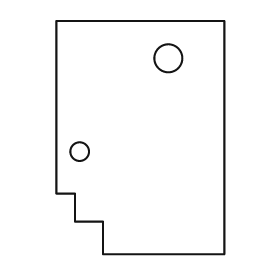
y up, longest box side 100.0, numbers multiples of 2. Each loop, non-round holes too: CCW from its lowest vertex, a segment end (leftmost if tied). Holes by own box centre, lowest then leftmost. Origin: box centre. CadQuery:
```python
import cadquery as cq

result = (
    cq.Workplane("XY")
    .moveTo(-16.0, -50.0)
    .lineTo(36.0, -50.0)
    .lineTo(36.0, 50.0)
    .lineTo(-36.0, 50.0)
    .lineTo(-36.0, -24.0)
    .lineTo(-28.0, -24.0)
    .lineTo(-28.0, -36.0)
    .lineTo(-16.0, -36.0)
    .close()
    .moveTo(-26.0, -6.0)
    .circle(4.0)
    .moveTo(12.0, 34.0)
    .circle(6.0)
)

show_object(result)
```